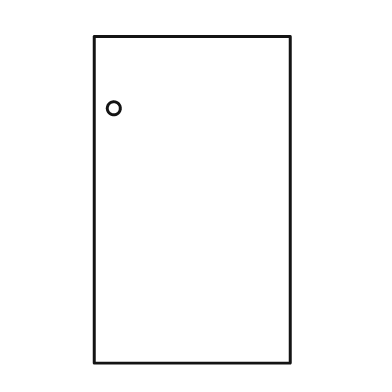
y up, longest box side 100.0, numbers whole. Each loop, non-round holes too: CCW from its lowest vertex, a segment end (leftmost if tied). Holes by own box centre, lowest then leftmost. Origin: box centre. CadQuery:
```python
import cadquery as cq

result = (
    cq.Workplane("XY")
    .moveTo(-30.0, -50.0)
    .lineTo(30.0, -50.0)
    .lineTo(30.0, 50.0)
    .lineTo(-30.0, 50.0)
    .close()
    .moveTo(-24.0, 28.0)
    .circle(2.0)
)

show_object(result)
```